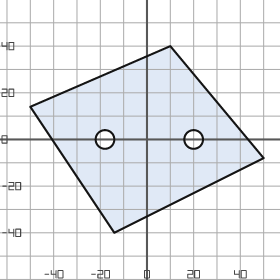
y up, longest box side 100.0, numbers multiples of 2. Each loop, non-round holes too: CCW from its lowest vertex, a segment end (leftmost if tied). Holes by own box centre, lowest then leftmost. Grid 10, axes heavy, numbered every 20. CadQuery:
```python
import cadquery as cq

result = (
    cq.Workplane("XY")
    .moveTo(-14.0, -40.0)
    .lineTo(50.0, -8.0)
    .lineTo(10.0, 40.0)
    .lineTo(-50.0, 14.0)
    .close()
    .moveTo(-18.0, 0.0)
    .circle(4.0)
    .moveTo(20.0, 0.0)
    .circle(4.0)
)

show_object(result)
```